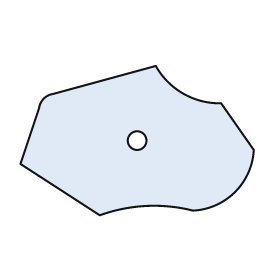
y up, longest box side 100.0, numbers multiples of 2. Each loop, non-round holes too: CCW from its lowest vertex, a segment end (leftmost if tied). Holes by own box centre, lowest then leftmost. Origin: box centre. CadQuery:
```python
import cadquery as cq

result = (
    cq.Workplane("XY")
    .moveTo(-16.0, -32.0)
    .threePointArc((4.0, -28.0), (24.0, -30.0))
    .threePointArc((42.0, -22.0), (50.0, -4.0))
    .lineTo(36.0, 16.0)
    .threePointArc((20.0, 20.0), (8.0, 32.0))
    .lineTo(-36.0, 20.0)
    .threePointArc((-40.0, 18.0), (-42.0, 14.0))
    .lineTo(-50.0, -10.0)
    .close()
    .moveTo(0.0, 0.0)
    .circle(4.0)
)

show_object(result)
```